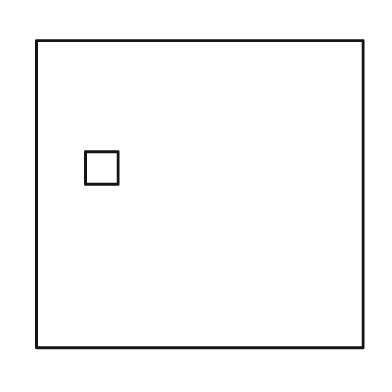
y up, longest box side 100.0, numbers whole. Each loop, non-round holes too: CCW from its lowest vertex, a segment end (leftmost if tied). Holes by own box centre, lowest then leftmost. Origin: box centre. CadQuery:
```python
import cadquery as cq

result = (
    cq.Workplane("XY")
    .moveTo(-50.0, -47.0)
    .lineTo(50.0, -47.0)
    .lineTo(50.0, 47.0)
    .lineTo(-50.0, 47.0)
    .close()
    .moveTo(-35.0, 3.0)
    .lineTo(-25.0, 3.0)
    .lineTo(-25.0, 13.0)
    .lineTo(-35.0, 13.0)
    .close()
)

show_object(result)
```